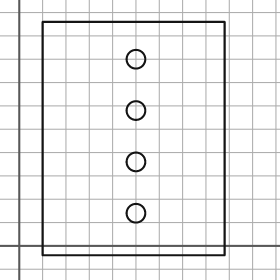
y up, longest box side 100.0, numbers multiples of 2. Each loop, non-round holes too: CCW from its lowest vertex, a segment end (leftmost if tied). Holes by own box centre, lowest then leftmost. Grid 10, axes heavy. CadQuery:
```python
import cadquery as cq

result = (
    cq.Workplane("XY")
    .moveTo(10.0, -4.0)
    .lineTo(88.0, -4.0)
    .lineTo(88.0, 96.0)
    .lineTo(10.0, 96.0)
    .close()
    .moveTo(50.0, 14.0)
    .circle(4.0)
    .moveTo(50.0, 36.0)
    .circle(4.0)
    .moveTo(50.0, 58.0)
    .circle(4.0)
    .moveTo(50.0, 80.0)
    .circle(4.0)
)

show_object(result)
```